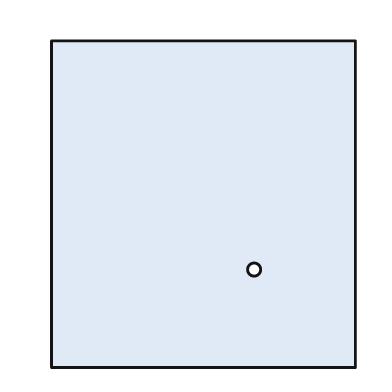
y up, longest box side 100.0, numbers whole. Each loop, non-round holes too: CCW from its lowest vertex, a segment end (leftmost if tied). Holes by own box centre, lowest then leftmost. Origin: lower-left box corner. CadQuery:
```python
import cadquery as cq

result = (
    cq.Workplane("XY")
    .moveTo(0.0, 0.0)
    .lineTo(93.0, 0.0)
    .lineTo(93.0, 100.0)
    .lineTo(0.0, 100.0)
    .close()
    .moveTo(62.0, 30.0)
    .circle(2.0)
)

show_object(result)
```